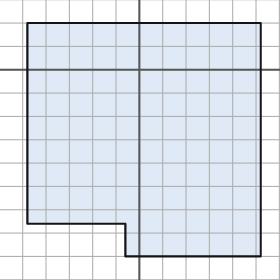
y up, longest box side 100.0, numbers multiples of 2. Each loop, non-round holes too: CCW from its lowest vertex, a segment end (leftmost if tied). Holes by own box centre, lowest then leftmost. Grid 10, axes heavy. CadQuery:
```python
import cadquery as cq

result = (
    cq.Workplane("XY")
    .moveTo(-6.0, -80.0)
    .lineTo(52.0, -80.0)
    .lineTo(52.0, 20.0)
    .lineTo(-48.0, 20.0)
    .lineTo(-48.0, -66.0)
    .lineTo(-6.0, -66.0)
    .close()
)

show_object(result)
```